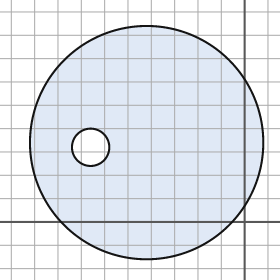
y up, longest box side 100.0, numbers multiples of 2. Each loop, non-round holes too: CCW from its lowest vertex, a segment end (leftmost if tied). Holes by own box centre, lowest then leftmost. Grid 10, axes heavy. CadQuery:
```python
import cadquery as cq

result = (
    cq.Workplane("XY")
    .moveTo(-42.0, 34.0)
    .circle(50.0)
    .moveTo(-66.0, 32.0)
    .circle(8.0)
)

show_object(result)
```